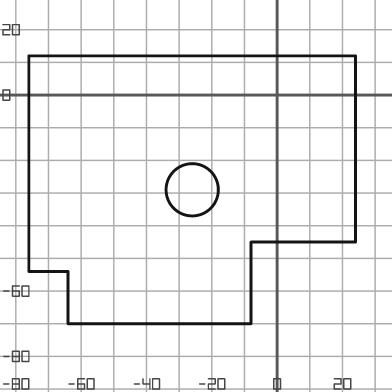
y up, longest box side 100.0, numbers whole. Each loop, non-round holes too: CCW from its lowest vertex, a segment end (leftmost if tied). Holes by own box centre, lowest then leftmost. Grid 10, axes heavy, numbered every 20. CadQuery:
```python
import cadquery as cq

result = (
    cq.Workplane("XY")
    .moveTo(-64.0, -70.0)
    .lineTo(-8.0, -70.0)
    .lineTo(-8.0, -45.0)
    .lineTo(24.0, -45.0)
    .lineTo(24.0, 12.0)
    .lineTo(-76.0, 12.0)
    .lineTo(-76.0, -54.0)
    .lineTo(-64.0, -54.0)
    .close()
    .moveTo(-26.0, -29.0)
    .circle(8.0)
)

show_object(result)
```